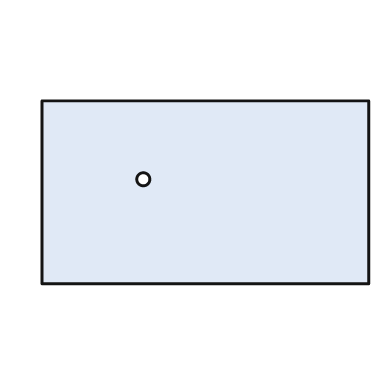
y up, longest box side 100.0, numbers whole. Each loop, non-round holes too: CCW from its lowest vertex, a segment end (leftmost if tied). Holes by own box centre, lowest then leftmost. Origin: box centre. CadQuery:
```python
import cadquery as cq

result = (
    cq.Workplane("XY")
    .moveTo(-50.0, -28.0)
    .lineTo(50.0, -28.0)
    .lineTo(50.0, 28.0)
    .lineTo(-50.0, 28.0)
    .close()
    .moveTo(-19.0, 4.0)
    .circle(2.0)
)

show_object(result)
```